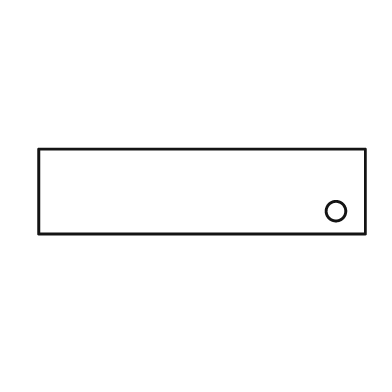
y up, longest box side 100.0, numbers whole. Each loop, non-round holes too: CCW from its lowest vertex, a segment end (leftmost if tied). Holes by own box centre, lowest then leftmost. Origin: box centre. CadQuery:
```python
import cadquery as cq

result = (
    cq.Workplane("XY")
    .moveTo(-50.0, -13.0)
    .lineTo(50.0, -13.0)
    .lineTo(50.0, 13.0)
    .lineTo(-50.0, 13.0)
    .close()
    .moveTo(41.0, -6.0)
    .circle(3.0)
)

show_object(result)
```